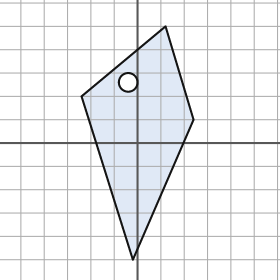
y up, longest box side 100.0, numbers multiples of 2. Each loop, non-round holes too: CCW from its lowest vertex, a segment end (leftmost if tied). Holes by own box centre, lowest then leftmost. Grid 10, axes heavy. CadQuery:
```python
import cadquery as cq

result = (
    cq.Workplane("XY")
    .moveTo(-2.0, -50.0)
    .lineTo(24.0, 10.0)
    .lineTo(12.0, 50.0)
    .lineTo(-24.0, 20.0)
    .close()
    .moveTo(-4.0, 26.0)
    .circle(4.0)
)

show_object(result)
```